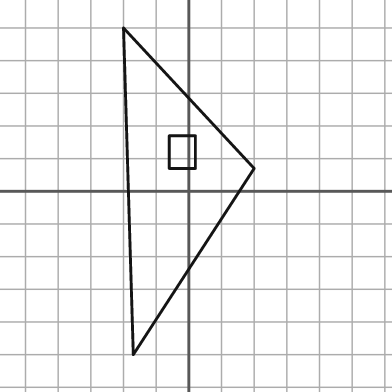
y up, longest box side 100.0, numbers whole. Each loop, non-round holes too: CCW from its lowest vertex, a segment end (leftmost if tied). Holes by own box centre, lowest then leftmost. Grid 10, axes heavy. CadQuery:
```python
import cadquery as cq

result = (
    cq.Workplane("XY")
    .moveTo(-17.0, -50.0)
    .lineTo(20.0, 7.0)
    .lineTo(-20.0, 50.0)
    .close()
    .moveTo(-6.0, 7.0)
    .lineTo(2.0, 7.0)
    .lineTo(2.0, 17.0)
    .lineTo(-6.0, 17.0)
    .close()
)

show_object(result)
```